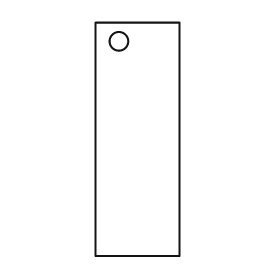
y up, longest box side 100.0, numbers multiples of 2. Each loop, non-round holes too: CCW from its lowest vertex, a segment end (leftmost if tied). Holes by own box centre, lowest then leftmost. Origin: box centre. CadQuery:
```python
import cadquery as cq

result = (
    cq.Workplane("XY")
    .moveTo(-18.0, -50.0)
    .lineTo(18.0, -50.0)
    .lineTo(18.0, 50.0)
    .lineTo(-18.0, 50.0)
    .close()
    .moveTo(-8.0, 42.0)
    .circle(4.0)
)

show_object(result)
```